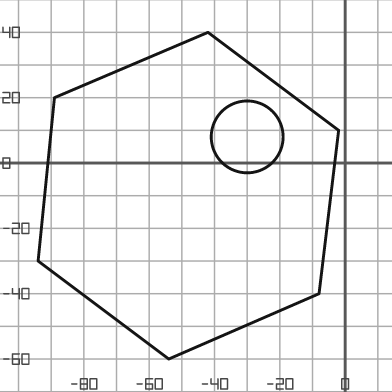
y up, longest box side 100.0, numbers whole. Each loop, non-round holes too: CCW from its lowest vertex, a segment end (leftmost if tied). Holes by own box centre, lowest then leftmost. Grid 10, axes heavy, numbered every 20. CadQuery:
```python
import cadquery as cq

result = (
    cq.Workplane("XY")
    .moveTo(-54.0, -60.0)
    .lineTo(-8.0, -40.0)
    .lineTo(-2.0, 10.0)
    .lineTo(-42.0, 40.0)
    .lineTo(-89.0, 20.0)
    .lineTo(-94.0, -30.0)
    .close()
    .moveTo(-30.0, 8.0)
    .circle(11.0)
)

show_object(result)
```